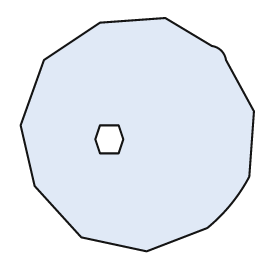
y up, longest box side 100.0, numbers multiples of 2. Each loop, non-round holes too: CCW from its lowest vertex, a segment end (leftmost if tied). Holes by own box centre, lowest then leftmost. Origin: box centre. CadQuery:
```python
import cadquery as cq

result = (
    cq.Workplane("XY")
    .moveTo(4.0, -50.0)
    .lineTo(30.0, -40.0)
    .threePointArc((40.0, -30.0), (48.0, -18.0))
    .lineTo(50.0, 10.0)
    .lineTo(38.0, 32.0)
    .threePointArc((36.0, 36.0), (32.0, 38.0))
    .lineTo(12.0, 50.0)
    .lineTo(-16.0, 48.0)
    .lineTo(-40.0, 32.0)
    .lineTo(-50.0, 4.0)
    .lineTo(-44.0, -22.0)
    .lineTo(-24.0, -44.0)
    .close()
    .moveTo(-16.0, -8.0)
    .lineTo(-8.0, -8.0)
    .lineTo(-6.0, -2.0)
    .lineTo(-8.0, 4.0)
    .lineTo(-16.0, 4.0)
    .lineTo(-18.0, -2.0)
    .close()
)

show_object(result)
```